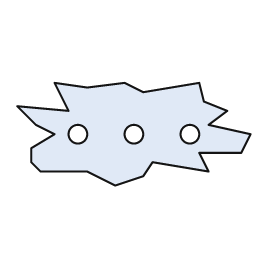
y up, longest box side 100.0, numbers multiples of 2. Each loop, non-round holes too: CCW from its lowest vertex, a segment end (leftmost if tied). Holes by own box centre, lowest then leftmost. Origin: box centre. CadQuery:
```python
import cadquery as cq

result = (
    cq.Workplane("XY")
    .moveTo(-8.0, -22.0)
    .lineTo(4.0, -18.0)
    .lineTo(8.0, -12.0)
    .lineTo(32.0, -16.0)
    .lineTo(28.0, -8.0)
    .lineTo(46.0, -8.0)
    .lineTo(50.0, 0.0)
    .lineTo(32.0, 4.0)
    .lineTo(40.0, 10.0)
    .lineTo(30.0, 14.0)
    .lineTo(28.0, 22.0)
    .lineTo(4.0, 18.0)
    .lineTo(-4.0, 22.0)
    .lineTo(-20.0, 20.0)
    .lineTo(-34.0, 22.0)
    .lineTo(-28.0, 10.0)
    .lineTo(-50.0, 12.0)
    .lineTo(-42.0, 4.0)
    .lineTo(-34.0, 0.0)
    .lineTo(-44.0, -6.0)
    .lineTo(-44.0, -12.0)
    .lineTo(-40.0, -16.0)
    .lineTo(-20.0, -16.0)
    .close()
    .moveTo(-24.0, 0.0)
    .circle(4.0)
    .moveTo(0.0, 0.0)
    .circle(4.0)
    .moveTo(24.0, 0.0)
    .circle(4.0)
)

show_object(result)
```